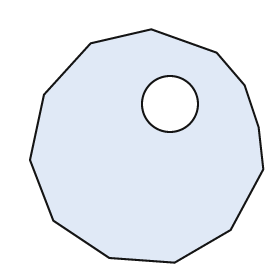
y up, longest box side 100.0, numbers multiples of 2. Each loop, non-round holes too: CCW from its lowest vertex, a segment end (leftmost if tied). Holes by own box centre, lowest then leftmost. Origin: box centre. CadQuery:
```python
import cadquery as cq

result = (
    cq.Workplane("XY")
    .moveTo(12.0, -50.0)
    .lineTo(36.0, -36.0)
    .lineTo(50.0, -10.0)
    .lineTo(48.0, 8.0)
    .lineTo(42.0, 26.0)
    .lineTo(30.0, 40.0)
    .lineTo(2.0, 50.0)
    .lineTo(-24.0, 44.0)
    .lineTo(-44.0, 22.0)
    .lineTo(-50.0, -6.0)
    .lineTo(-40.0, -32.0)
    .lineTo(-16.0, -48.0)
    .close()
    .moveTo(10.0, 18.0)
    .circle(12.0)
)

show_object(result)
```